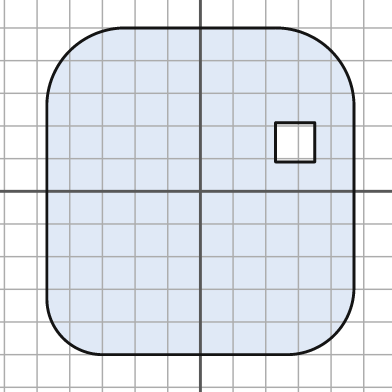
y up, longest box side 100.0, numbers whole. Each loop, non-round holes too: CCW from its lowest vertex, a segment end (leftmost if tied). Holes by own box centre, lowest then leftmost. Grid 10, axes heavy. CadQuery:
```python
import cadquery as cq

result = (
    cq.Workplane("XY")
    .moveTo(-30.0, -50.0)
    .lineTo(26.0, -50.0)
    .threePointArc((41.0, -44.0), (47.0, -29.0))
    .lineTo(47.0, 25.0)
    .threePointArc((40.0, 43.0), (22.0, 50.0))
    .lineTo(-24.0, 50.0)
    .threePointArc((-40.0, 43.0), (-47.0, 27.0))
    .lineTo(-47.0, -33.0)
    .threePointArc((-42.0, -45.0), (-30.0, -50.0))
    .close()
    .moveTo(23.0, 9.0)
    .lineTo(35.0, 9.0)
    .lineTo(35.0, 21.0)
    .lineTo(23.0, 21.0)
    .close()
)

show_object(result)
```